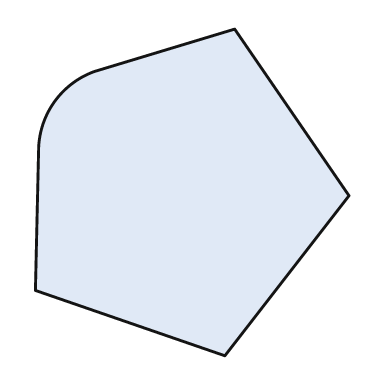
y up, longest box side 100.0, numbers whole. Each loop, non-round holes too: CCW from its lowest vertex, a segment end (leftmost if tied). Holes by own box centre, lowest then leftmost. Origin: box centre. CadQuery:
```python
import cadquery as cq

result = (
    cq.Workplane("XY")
    .moveTo(10.0, -50.0)
    .lineTo(48.0, -1.0)
    .lineTo(13.0, 50.0)
    .lineTo(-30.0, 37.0)
    .threePointArc((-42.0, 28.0), (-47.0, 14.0))
    .lineTo(-48.0, -30.0)
    .close()
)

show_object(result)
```